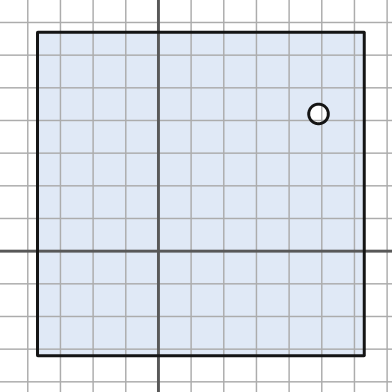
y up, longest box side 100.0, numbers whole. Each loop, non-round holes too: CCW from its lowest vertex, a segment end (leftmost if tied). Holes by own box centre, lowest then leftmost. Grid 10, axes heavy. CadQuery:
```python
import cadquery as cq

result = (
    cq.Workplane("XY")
    .moveTo(-37.0, -32.0)
    .lineTo(63.0, -32.0)
    .lineTo(63.0, 67.0)
    .lineTo(-37.0, 67.0)
    .close()
    .moveTo(49.0, 42.0)
    .circle(3.0)
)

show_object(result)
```